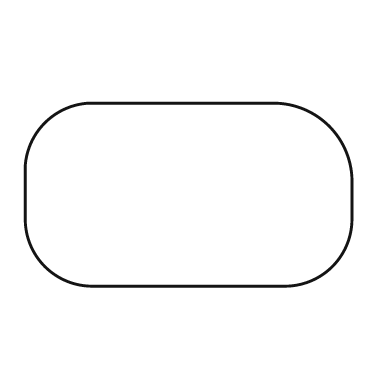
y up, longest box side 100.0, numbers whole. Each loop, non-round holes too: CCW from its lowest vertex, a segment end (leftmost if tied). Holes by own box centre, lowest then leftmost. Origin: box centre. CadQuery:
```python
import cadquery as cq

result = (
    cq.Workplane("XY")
    .moveTo(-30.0, -28.0)
    .lineTo(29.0, -28.0)
    .threePointArc((44.0, -22.0), (50.0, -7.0))
    .lineTo(50.0, 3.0)
    .threePointArc((43.0, 21.0), (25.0, 28.0))
    .lineTo(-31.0, 28.0)
    .threePointArc((-44.0, 22.0), (-50.0, 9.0))
    .lineTo(-50.0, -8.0)
    .threePointArc((-44.0, -22.0), (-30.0, -28.0))
    .close()
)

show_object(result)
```